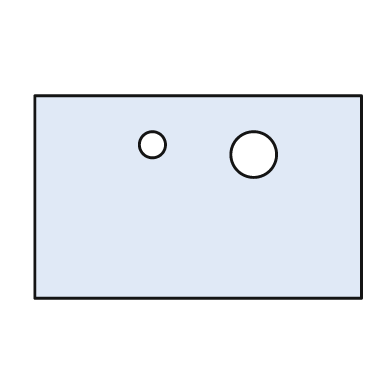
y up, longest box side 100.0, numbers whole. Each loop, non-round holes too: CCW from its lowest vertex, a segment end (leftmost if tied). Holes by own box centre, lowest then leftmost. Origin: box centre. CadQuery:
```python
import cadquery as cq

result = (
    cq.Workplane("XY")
    .moveTo(-50.0, -31.0)
    .lineTo(50.0, -31.0)
    .lineTo(50.0, 31.0)
    .lineTo(-50.0, 31.0)
    .close()
    .moveTo(17.0, 13.0)
    .circle(7.0)
    .moveTo(-14.0, 16.0)
    .circle(4.0)
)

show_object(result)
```